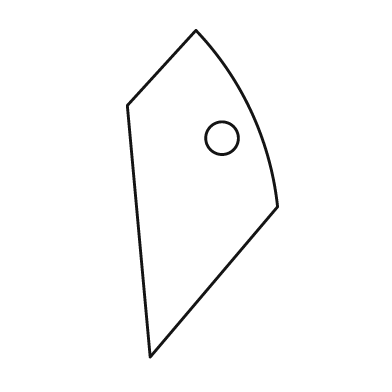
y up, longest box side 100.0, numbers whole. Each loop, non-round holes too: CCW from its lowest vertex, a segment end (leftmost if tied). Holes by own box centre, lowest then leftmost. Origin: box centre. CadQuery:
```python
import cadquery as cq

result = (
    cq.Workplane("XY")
    .moveTo(-16.0, -50.0)
    .lineTo(23.0, -4.0)
    .threePointArc((15.0, 25.0), (-2.0, 50.0))
    .lineTo(-23.0, 27.0)
    .close()
    .moveTo(6.0, 17.0)
    .circle(5.0)
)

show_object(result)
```